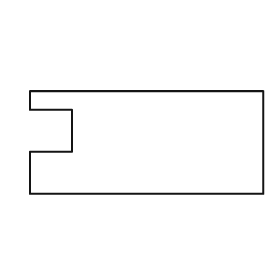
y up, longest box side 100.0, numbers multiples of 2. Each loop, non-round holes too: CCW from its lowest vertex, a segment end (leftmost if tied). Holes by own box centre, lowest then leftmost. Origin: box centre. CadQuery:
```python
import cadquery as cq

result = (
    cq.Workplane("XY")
    .moveTo(-50.0, -22.0)
    .lineTo(50.0, -22.0)
    .lineTo(50.0, 22.0)
    .lineTo(-50.0, 22.0)
    .lineTo(-50.0, 14.0)
    .lineTo(-32.0, 14.0)
    .lineTo(-32.0, -4.0)
    .lineTo(-50.0, -4.0)
    .close()
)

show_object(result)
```